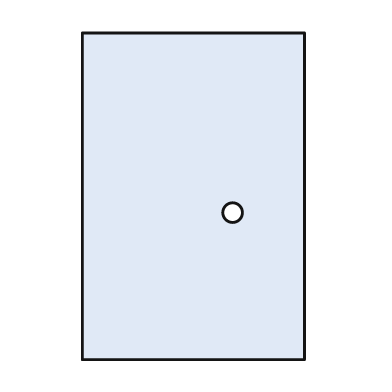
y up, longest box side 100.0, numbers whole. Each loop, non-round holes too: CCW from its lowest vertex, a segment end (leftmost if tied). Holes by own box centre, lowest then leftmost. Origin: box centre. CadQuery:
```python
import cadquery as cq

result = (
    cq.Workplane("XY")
    .moveTo(-34.0, -50.0)
    .lineTo(34.0, -50.0)
    .lineTo(34.0, 50.0)
    .lineTo(-34.0, 50.0)
    .close()
    .moveTo(12.0, -5.0)
    .circle(3.0)
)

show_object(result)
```